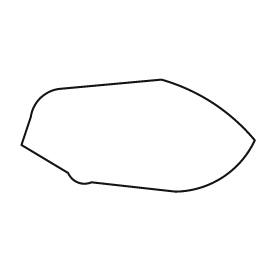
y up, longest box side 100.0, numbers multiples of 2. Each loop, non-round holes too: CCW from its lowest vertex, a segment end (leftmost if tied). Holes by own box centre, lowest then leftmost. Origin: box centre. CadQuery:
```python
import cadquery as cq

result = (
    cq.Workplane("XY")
    .moveTo(16.0, -24.0)
    .threePointArc((36.0, -18.0), (50.0, -2.0))
    .threePointArc((32.0, 14.0), (10.0, 24.0))
    .lineTo(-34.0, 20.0)
    .threePointArc((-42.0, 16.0), (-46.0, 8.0))
    .lineTo(-50.0, -4.0)
    .lineTo(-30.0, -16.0)
    .threePointArc((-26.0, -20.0), (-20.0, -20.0))
    .close()
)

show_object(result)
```